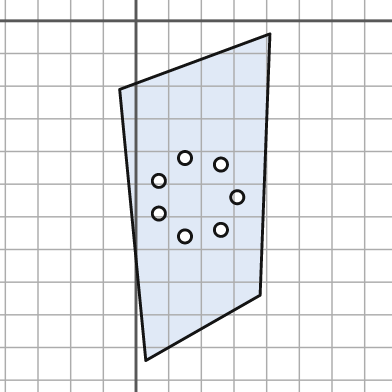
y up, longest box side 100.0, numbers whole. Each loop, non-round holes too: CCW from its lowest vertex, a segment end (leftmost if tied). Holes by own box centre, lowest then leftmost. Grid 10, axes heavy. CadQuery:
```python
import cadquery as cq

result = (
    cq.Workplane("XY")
    .moveTo(3.0, -104.0)
    .lineTo(38.0, -84.0)
    .lineTo(41.0, -4.0)
    .lineTo(-5.0, -21.0)
    .close()
    .moveTo(15.0, -66.0)
    .circle(2.0)
    .moveTo(26.0, -64.0)
    .circle(2.0)
    .moveTo(7.0, -59.0)
    .circle(2.0)
    .moveTo(31.0, -54.0)
    .circle(2.0)
    .moveTo(7.0, -49.0)
    .circle(2.0)
    .moveTo(26.0, -44.0)
    .circle(2.0)
    .moveTo(15.0, -42.0)
    .circle(2.0)
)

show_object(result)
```